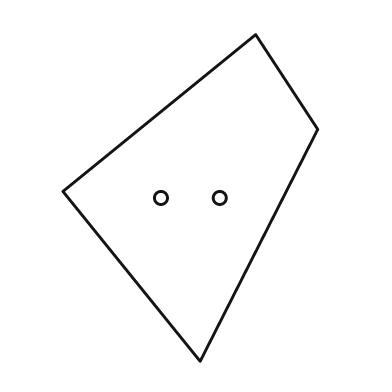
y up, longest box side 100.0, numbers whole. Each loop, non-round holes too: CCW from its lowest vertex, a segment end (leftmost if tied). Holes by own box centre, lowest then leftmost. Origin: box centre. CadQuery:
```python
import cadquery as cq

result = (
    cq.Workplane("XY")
    .moveTo(3.0, -50.0)
    .lineTo(39.0, 21.0)
    .lineTo(20.0, 50.0)
    .lineTo(-39.0, 2.0)
    .close()
    .moveTo(-9.0, 0.0)
    .circle(2.0)
    .moveTo(9.0, 0.0)
    .circle(2.0)
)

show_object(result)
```